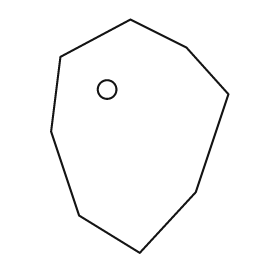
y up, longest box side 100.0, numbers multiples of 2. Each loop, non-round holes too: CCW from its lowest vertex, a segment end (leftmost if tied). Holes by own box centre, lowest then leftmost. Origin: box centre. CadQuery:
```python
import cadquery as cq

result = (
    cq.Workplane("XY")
    .moveTo(0.0, -50.0)
    .lineTo(24.0, -24.0)
    .lineTo(38.0, 18.0)
    .lineTo(20.0, 38.0)
    .lineTo(-4.0, 50.0)
    .lineTo(-34.0, 34.0)
    .lineTo(-38.0, 2.0)
    .lineTo(-26.0, -34.0)
    .close()
    .moveTo(-14.0, 20.0)
    .circle(4.0)
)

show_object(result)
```